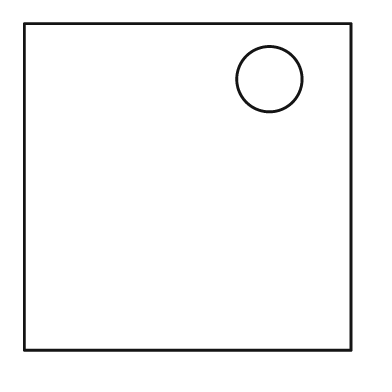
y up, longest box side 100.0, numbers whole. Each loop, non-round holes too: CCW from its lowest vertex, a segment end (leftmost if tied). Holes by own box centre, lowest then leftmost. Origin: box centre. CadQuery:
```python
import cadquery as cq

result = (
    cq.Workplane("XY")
    .moveTo(-50.0, -50.0)
    .lineTo(50.0, -50.0)
    .lineTo(50.0, 50.0)
    .lineTo(-50.0, 50.0)
    .close()
    .moveTo(25.0, 33.0)
    .circle(10.0)
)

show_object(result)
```